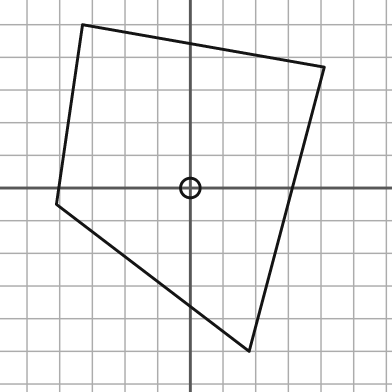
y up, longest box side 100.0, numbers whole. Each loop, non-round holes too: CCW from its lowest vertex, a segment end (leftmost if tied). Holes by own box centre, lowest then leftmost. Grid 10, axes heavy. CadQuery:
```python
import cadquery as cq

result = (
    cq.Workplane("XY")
    .moveTo(18.0, -50.0)
    .lineTo(41.0, 37.0)
    .lineTo(-33.0, 50.0)
    .lineTo(-41.0, -5.0)
    .close()
    .moveTo(0.0, 0.0)
    .circle(3.0)
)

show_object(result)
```